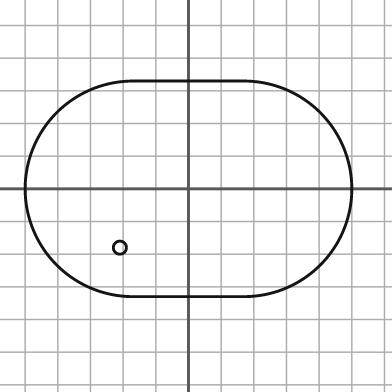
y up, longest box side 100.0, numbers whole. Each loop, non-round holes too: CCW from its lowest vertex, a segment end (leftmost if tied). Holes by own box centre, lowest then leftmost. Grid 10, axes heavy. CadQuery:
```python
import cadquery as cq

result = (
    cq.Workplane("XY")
    .moveTo(-17.0, -33.0)
    .lineTo(17.0, -33.0)
    .threePointArc((50.0, 0.0), (17.0, 33.0))
    .lineTo(-17.0, 33.0)
    .threePointArc((-50.0, 0.0), (-17.0, -33.0))
    .close()
    .moveTo(-21.0, -18.0)
    .circle(2.0)
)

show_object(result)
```